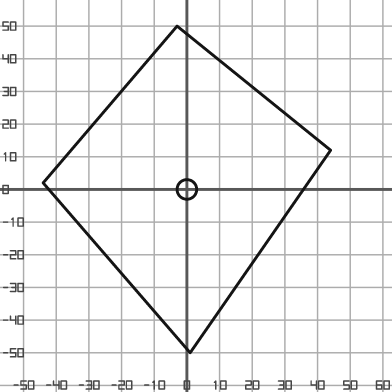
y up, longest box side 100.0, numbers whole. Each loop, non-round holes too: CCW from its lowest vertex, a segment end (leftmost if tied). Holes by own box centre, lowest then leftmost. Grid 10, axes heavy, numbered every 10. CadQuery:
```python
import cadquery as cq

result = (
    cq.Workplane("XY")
    .moveTo(1.0, -50.0)
    .lineTo(44.0, 12.0)
    .lineTo(-3.0, 50.0)
    .lineTo(-44.0, 2.0)
    .close()
    .moveTo(0.0, 0.0)
    .circle(3.0)
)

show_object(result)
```